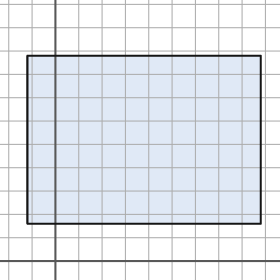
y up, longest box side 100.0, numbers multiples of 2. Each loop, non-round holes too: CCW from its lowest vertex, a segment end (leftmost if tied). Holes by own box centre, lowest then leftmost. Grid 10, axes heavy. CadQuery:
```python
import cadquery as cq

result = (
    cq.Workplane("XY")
    .moveTo(-12.0, 16.0)
    .lineTo(88.0, 16.0)
    .lineTo(88.0, 88.0)
    .lineTo(-12.0, 88.0)
    .close()
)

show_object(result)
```